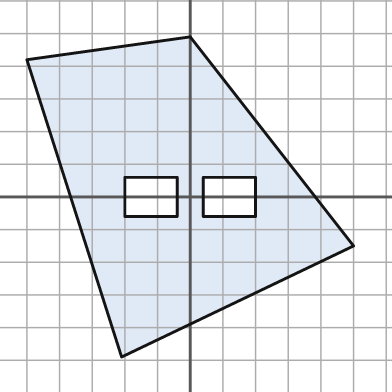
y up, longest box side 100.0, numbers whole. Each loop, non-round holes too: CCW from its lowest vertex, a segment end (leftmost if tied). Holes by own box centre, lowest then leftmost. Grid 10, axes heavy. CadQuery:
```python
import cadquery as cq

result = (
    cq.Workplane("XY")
    .moveTo(-21.0, -49.0)
    .lineTo(50.0, -15.0)
    .lineTo(0.0, 49.0)
    .lineTo(-50.0, 42.0)
    .close()
    .moveTo(-20.0, -6.0)
    .lineTo(-4.0, -6.0)
    .lineTo(-4.0, 6.0)
    .lineTo(-20.0, 6.0)
    .close()
    .moveTo(4.0, -6.0)
    .lineTo(20.0, -6.0)
    .lineTo(20.0, 6.0)
    .lineTo(4.0, 6.0)
    .close()
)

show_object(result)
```